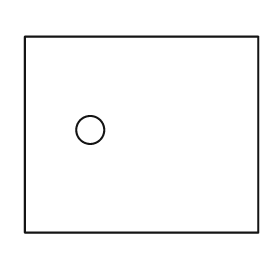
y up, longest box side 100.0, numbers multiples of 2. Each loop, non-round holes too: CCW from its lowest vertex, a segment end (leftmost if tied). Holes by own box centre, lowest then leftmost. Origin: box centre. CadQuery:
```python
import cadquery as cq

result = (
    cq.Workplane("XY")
    .moveTo(-50.0, -42.0)
    .lineTo(50.0, -42.0)
    .lineTo(50.0, 42.0)
    .lineTo(-50.0, 42.0)
    .close()
    .moveTo(-22.0, 2.0)
    .circle(6.0)
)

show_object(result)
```